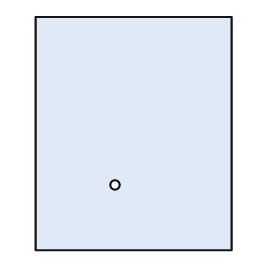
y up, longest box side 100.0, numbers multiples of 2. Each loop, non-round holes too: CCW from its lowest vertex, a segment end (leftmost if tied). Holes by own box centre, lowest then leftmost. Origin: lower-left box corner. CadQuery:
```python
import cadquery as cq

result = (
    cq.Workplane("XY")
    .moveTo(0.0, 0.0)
    .lineTo(84.0, 0.0)
    .lineTo(84.0, 100.0)
    .lineTo(0.0, 100.0)
    .close()
    .moveTo(34.0, 28.0)
    .circle(2.0)
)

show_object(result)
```